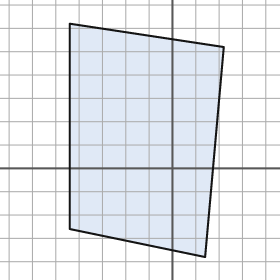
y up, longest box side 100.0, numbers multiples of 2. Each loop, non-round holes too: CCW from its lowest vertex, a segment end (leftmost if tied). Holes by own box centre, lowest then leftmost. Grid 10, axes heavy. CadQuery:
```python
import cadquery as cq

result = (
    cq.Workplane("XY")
    .moveTo(14.0, -38.0)
    .lineTo(22.0, 52.0)
    .lineTo(-44.0, 62.0)
    .lineTo(-44.0, -26.0)
    .close()
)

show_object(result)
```